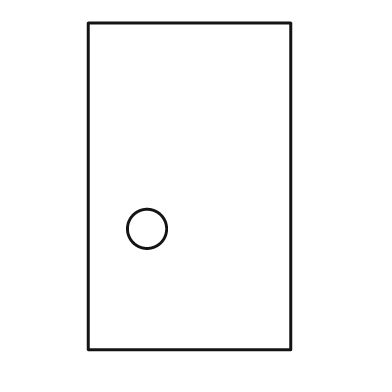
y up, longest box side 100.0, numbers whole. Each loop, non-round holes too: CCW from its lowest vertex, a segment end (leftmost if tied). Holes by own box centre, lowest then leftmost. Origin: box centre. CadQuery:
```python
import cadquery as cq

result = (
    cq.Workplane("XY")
    .moveTo(-31.0, -50.0)
    .lineTo(31.0, -50.0)
    .lineTo(31.0, 50.0)
    .lineTo(-31.0, 50.0)
    .close()
    .moveTo(-13.0, -13.0)
    .circle(6.0)
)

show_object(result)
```